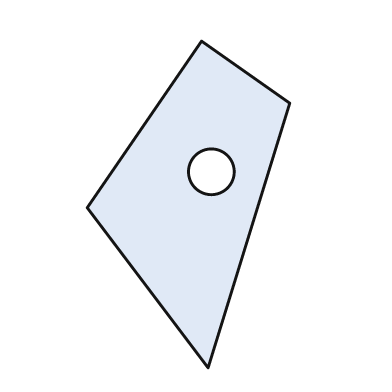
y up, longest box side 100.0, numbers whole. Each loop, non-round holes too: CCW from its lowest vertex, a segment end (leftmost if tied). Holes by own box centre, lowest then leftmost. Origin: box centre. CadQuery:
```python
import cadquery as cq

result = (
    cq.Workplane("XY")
    .moveTo(6.0, -50.0)
    .lineTo(31.0, 31.0)
    .lineTo(4.0, 50.0)
    .lineTo(-31.0, -1.0)
    .close()
    .moveTo(7.0, 10.0)
    .circle(7.0)
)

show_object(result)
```